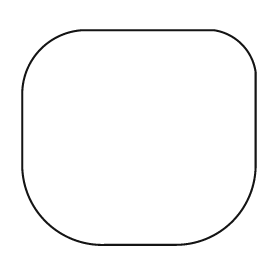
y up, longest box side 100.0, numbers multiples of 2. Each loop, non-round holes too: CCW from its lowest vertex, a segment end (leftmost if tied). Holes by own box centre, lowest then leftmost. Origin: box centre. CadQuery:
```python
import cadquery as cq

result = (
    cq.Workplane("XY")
    .moveTo(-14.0, -46.0)
    .lineTo(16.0, -46.0)
    .threePointArc((40.0, -36.0), (50.0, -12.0))
    .lineTo(50.0, 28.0)
    .threePointArc((44.0, 40.0), (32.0, 46.0))
    .lineTo(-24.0, 46.0)
    .threePointArc((-42.0, 38.0), (-50.0, 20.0))
    .lineTo(-50.0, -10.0)
    .threePointArc((-40.0, -36.0), (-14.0, -46.0))
    .close()
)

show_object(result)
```